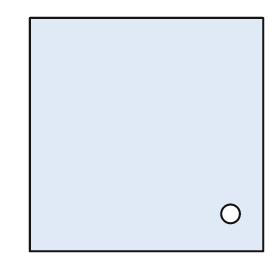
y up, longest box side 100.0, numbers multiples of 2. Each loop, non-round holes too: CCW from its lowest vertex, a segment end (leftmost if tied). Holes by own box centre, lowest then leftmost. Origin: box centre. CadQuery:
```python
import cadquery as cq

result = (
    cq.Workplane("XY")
    .moveTo(-50.0, -50.0)
    .lineTo(50.0, -50.0)
    .lineTo(50.0, 50.0)
    .lineTo(-50.0, 50.0)
    .close()
    .moveTo(36.0, -34.0)
    .circle(4.0)
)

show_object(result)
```